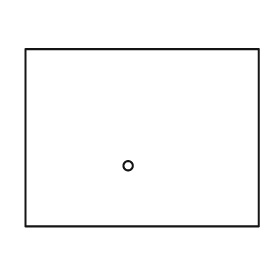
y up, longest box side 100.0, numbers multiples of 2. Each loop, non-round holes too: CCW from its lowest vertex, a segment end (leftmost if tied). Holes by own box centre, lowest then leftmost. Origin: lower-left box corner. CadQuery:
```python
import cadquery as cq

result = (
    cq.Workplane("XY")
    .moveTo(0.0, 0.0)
    .lineTo(100.0, 0.0)
    .lineTo(100.0, 76.0)
    .lineTo(0.0, 76.0)
    .close()
    .moveTo(44.0, 26.0)
    .circle(2.0)
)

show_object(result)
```